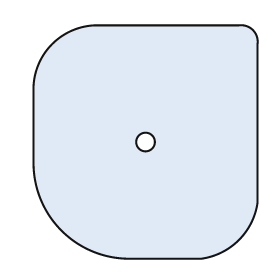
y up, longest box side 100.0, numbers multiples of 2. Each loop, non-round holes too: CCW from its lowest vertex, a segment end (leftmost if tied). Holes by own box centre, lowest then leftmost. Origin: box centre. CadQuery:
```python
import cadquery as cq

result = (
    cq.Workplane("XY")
    .moveTo(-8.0, -50.0)
    .lineTo(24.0, -50.0)
    .threePointArc((40.0, -42.0), (48.0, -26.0))
    .lineTo(48.0, 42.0)
    .threePointArc((46.0, 48.0), (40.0, 50.0))
    .lineTo(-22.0, 50.0)
    .threePointArc((-40.0, 42.0), (-48.0, 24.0))
    .lineTo(-48.0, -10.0)
    .threePointArc((-36.0, -38.0), (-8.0, -50.0))
    .close()
    .moveTo(0.0, 0.0)
    .circle(4.0)
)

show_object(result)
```